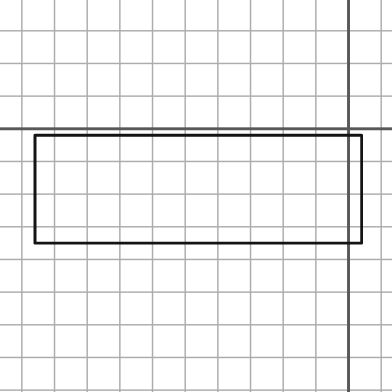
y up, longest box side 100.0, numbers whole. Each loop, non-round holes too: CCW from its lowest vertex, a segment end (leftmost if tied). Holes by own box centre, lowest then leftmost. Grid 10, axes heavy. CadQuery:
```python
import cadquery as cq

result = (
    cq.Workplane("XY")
    .moveTo(-96.0, -35.0)
    .lineTo(4.0, -35.0)
    .lineTo(4.0, -2.0)
    .lineTo(-96.0, -2.0)
    .close()
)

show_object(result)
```